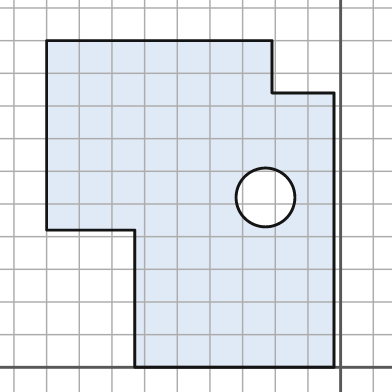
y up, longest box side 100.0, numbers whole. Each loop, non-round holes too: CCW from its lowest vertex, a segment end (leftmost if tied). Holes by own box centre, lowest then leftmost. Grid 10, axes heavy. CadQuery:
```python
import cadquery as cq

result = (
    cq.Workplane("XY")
    .moveTo(-63.0, 0.0)
    .lineTo(-2.0, 0.0)
    .lineTo(-2.0, 84.0)
    .lineTo(-21.0, 84.0)
    .lineTo(-21.0, 100.0)
    .lineTo(-90.0, 100.0)
    .lineTo(-90.0, 42.0)
    .lineTo(-63.0, 42.0)
    .close()
    .moveTo(-23.0, 52.0)
    .circle(9.0)
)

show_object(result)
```